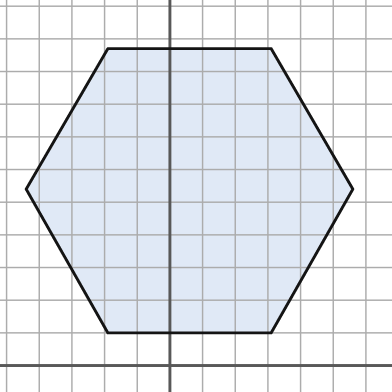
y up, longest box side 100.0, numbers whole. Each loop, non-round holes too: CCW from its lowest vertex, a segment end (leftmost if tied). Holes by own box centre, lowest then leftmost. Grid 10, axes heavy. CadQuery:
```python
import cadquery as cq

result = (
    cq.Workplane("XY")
    .moveTo(-19.0, 10.0)
    .lineTo(31.0, 10.0)
    .lineTo(56.0, 54.0)
    .lineTo(31.0, 97.0)
    .lineTo(-19.0, 97.0)
    .lineTo(-44.0, 54.0)
    .close()
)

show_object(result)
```